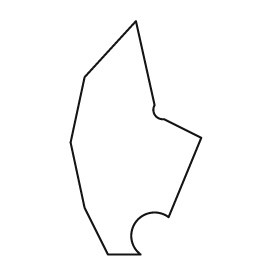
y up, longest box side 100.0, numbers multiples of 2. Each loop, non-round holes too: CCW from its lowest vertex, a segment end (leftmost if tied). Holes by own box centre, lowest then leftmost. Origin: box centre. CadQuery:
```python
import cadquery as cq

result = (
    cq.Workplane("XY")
    .moveTo(-12.0, -50.0)
    .lineTo(2.0, -50.0)
    .threePointArc((0.0, -36.0), (14.0, -34.0))
    .lineTo(28.0, 0.0)
    .lineTo(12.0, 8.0)
    .threePointArc((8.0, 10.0), (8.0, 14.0))
    .lineTo(0.0, 50.0)
    .lineTo(-22.0, 26.0)
    .lineTo(-28.0, -2.0)
    .lineTo(-22.0, -30.0)
    .close()
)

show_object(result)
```